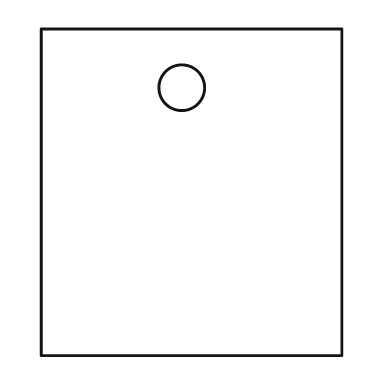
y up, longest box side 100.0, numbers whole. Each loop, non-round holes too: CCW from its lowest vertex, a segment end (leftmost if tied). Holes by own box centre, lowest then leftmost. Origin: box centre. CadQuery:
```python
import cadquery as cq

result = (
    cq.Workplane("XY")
    .moveTo(-46.0, -50.0)
    .lineTo(46.0, -50.0)
    .lineTo(46.0, 50.0)
    .lineTo(-46.0, 50.0)
    .close()
    .moveTo(-3.0, 32.0)
    .circle(7.0)
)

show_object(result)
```